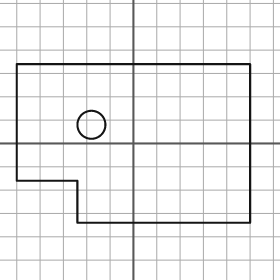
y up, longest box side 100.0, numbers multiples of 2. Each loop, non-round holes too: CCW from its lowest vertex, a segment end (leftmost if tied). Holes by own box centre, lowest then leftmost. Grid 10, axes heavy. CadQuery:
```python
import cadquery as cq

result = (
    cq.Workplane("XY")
    .moveTo(-24.0, -34.0)
    .lineTo(50.0, -34.0)
    .lineTo(50.0, 34.0)
    .lineTo(-50.0, 34.0)
    .lineTo(-50.0, -16.0)
    .lineTo(-24.0, -16.0)
    .close()
    .moveTo(-18.0, 8.0)
    .circle(6.0)
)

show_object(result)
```